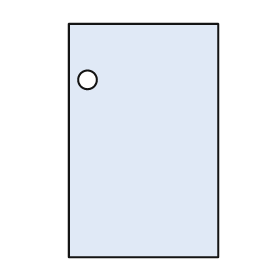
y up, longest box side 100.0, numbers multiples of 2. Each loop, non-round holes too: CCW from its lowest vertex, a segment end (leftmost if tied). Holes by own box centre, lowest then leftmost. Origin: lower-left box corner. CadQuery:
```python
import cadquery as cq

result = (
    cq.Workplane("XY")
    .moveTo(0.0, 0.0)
    .lineTo(64.0, 0.0)
    .lineTo(64.0, 100.0)
    .lineTo(0.0, 100.0)
    .close()
    .moveTo(8.0, 76.0)
    .circle(4.0)
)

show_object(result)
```